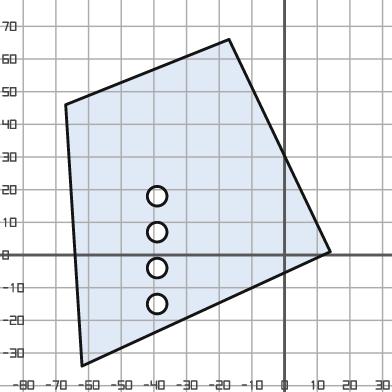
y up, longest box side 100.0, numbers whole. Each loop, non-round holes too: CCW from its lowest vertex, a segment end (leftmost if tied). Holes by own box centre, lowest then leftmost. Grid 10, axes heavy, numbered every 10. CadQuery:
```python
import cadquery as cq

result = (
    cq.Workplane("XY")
    .moveTo(-62.0, -34.0)
    .lineTo(14.0, 1.0)
    .lineTo(-17.0, 66.0)
    .lineTo(-67.0, 46.0)
    .close()
    .moveTo(-39.0, -15.0)
    .circle(3.0)
    .moveTo(-39.0, -4.0)
    .circle(3.0)
    .moveTo(-39.0, 7.0)
    .circle(3.0)
    .moveTo(-39.0, 18.0)
    .circle(3.0)
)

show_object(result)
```